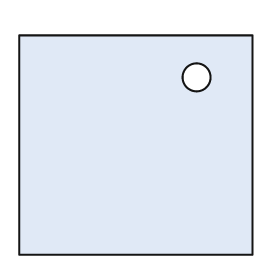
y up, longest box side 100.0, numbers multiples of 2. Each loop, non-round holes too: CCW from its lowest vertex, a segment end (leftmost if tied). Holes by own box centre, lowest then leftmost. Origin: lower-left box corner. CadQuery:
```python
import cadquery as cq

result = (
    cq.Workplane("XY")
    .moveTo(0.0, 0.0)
    .lineTo(100.0, 0.0)
    .lineTo(100.0, 94.0)
    .lineTo(0.0, 94.0)
    .close()
    .moveTo(76.0, 76.0)
    .circle(6.0)
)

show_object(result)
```